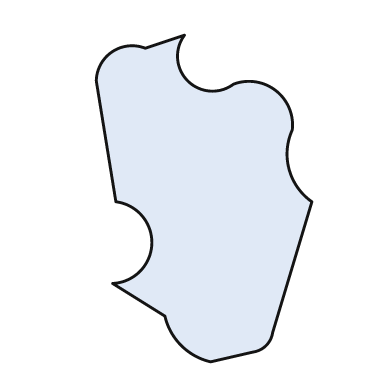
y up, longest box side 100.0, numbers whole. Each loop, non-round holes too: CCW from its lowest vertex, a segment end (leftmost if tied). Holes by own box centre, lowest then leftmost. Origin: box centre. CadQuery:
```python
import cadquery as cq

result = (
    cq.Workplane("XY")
    .moveTo(2.0, -50.0)
    .lineTo(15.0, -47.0)
    .threePointArc((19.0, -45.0), (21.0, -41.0))
    .lineTo(33.0, -1.0)
    .threePointArc((26.0, 9.0), (27.0, 21.0))
    .threePointArc((22.0, 33.0), (9.0, 35.0))
    .threePointArc((-5.0, 36.0), (-6.0, 50.0))
    .lineTo(-18.0, 46.0)
    .threePointArc((-28.0, 45.0), (-33.0, 36.0))
    .lineTo(-27.0, -1.0)
    .threePointArc((-16.0, -14.0), (-28.0, -26.0))
    .lineTo(-12.0, -36.0)
    .threePointArc((-7.0, -45.0), (2.0, -50.0))
    .close()
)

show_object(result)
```